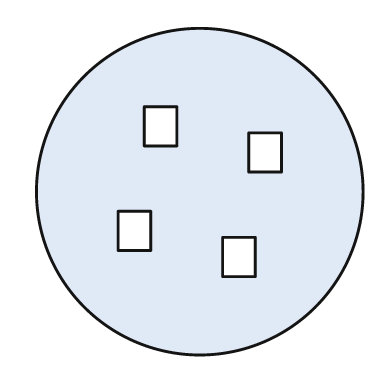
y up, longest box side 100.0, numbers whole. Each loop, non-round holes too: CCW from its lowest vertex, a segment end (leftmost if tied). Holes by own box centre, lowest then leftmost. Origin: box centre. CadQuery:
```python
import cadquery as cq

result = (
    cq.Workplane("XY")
    .moveTo(0.0, 0.0)
    .circle(50.0)
    .moveTo(7.0, -26.0)
    .lineTo(17.0, -26.0)
    .lineTo(17.0, -14.0)
    .lineTo(7.0, -14.0)
    .close()
    .moveTo(-25.0, -18.0)
    .lineTo(-15.0, -18.0)
    .lineTo(-15.0, -6.0)
    .lineTo(-25.0, -6.0)
    .close()
    .moveTo(15.0, 6.0)
    .lineTo(25.0, 6.0)
    .lineTo(25.0, 18.0)
    .lineTo(15.0, 18.0)
    .close()
    .moveTo(-17.0, 14.0)
    .lineTo(-7.0, 14.0)
    .lineTo(-7.0, 26.0)
    .lineTo(-17.0, 26.0)
    .close()
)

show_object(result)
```